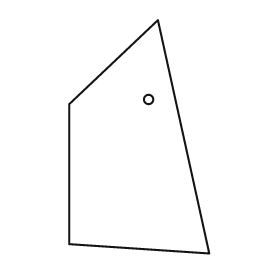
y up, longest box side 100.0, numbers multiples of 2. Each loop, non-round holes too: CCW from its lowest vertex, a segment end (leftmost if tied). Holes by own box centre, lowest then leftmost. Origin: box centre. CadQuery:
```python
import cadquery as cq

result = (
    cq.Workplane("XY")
    .moveTo(30.0, -50.0)
    .lineTo(8.0, 50.0)
    .lineTo(-30.0, 14.0)
    .lineTo(-30.0, -46.0)
    .close()
    .moveTo(4.0, 16.0)
    .circle(2.0)
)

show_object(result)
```